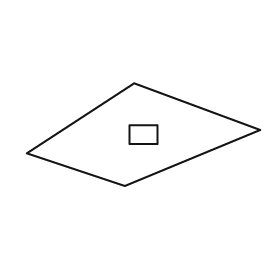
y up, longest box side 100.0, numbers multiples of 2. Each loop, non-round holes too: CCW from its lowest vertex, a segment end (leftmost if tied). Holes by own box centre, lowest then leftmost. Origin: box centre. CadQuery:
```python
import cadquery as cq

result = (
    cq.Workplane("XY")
    .moveTo(-8.0, -22.0)
    .lineTo(50.0, 2.0)
    .lineTo(-4.0, 22.0)
    .lineTo(-50.0, -8.0)
    .close()
    .moveTo(-6.0, -4.0)
    .lineTo(6.0, -4.0)
    .lineTo(6.0, 4.0)
    .lineTo(-6.0, 4.0)
    .close()
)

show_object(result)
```